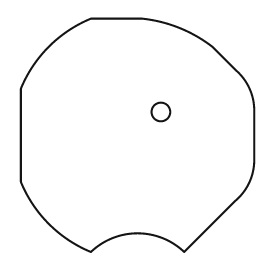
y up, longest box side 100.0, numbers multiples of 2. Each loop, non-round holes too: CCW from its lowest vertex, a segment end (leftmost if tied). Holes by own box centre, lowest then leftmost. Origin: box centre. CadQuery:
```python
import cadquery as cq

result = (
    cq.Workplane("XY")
    .moveTo(-20.0, -50.0)
    .threePointArc((0.0, -42.0), (20.0, -50.0))
    .lineTo(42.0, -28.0)
    .threePointArc((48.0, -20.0), (50.0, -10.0))
    .lineTo(50.0, 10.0)
    .threePointArc((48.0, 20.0), (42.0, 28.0))
    .lineTo(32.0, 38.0)
    .threePointArc((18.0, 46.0), (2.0, 50.0))
    .lineTo(-20.0, 50.0)
    .threePointArc((-38.0, 38.0), (-50.0, 20.0))
    .lineTo(-50.0, -20.0)
    .threePointArc((-38.0, -38.0), (-20.0, -50.0))
    .close()
    .moveTo(10.0, 10.0)
    .circle(4.0)
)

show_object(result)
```